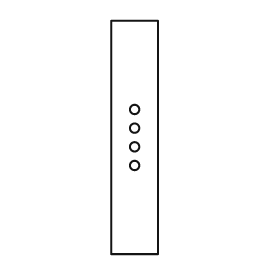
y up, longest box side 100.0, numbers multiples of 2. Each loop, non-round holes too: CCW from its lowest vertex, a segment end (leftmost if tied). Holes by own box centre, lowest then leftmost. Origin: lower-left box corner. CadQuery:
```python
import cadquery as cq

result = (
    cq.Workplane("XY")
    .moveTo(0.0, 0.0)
    .lineTo(20.0, 0.0)
    .lineTo(20.0, 100.0)
    .lineTo(0.0, 100.0)
    .close()
    .moveTo(10.0, 38.0)
    .circle(2.0)
    .moveTo(10.0, 46.0)
    .circle(2.0)
    .moveTo(10.0, 54.0)
    .circle(2.0)
    .moveTo(10.0, 62.0)
    .circle(2.0)
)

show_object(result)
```